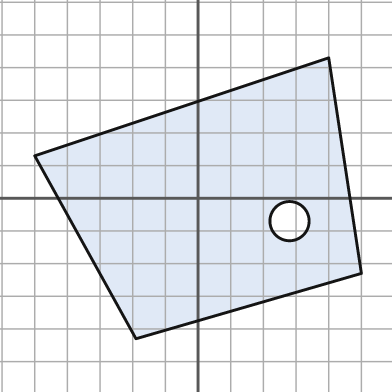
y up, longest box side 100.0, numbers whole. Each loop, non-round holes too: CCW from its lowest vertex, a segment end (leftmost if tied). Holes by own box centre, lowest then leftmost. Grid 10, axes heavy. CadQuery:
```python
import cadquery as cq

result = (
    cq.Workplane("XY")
    .moveTo(-19.0, -43.0)
    .lineTo(50.0, -23.0)
    .lineTo(40.0, 43.0)
    .lineTo(-50.0, 13.0)
    .close()
    .moveTo(28.0, -7.0)
    .circle(6.0)
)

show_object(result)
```